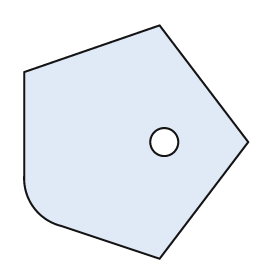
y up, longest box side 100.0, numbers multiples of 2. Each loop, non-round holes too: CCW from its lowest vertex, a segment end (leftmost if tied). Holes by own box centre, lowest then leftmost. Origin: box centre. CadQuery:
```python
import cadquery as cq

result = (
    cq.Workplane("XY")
    .moveTo(10.0, -50.0)
    .lineTo(48.0, 0.0)
    .lineTo(10.0, 50.0)
    .lineTo(-48.0, 30.0)
    .lineTo(-48.0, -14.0)
    .threePointArc((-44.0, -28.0), (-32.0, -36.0))
    .close()
    .moveTo(12.0, 0.0)
    .circle(6.0)
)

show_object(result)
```